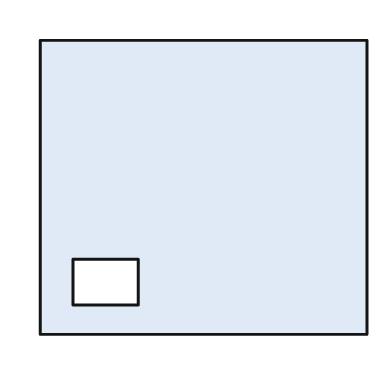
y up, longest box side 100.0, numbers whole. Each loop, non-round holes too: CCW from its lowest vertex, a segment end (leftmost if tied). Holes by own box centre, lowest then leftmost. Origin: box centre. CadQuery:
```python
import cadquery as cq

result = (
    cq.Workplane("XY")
    .moveTo(-50.0, -45.0)
    .lineTo(50.0, -45.0)
    .lineTo(50.0, 45.0)
    .lineTo(-50.0, 45.0)
    .close()
    .moveTo(-40.0, -36.0)
    .lineTo(-20.0, -36.0)
    .lineTo(-20.0, -22.0)
    .lineTo(-40.0, -22.0)
    .close()
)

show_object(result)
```